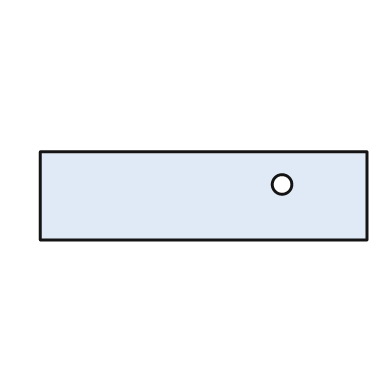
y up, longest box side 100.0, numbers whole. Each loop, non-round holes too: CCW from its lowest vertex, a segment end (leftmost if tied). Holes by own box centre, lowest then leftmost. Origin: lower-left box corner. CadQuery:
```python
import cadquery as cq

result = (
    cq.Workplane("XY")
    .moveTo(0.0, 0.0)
    .lineTo(100.0, 0.0)
    .lineTo(100.0, 27.0)
    .lineTo(0.0, 27.0)
    .close()
    .moveTo(74.0, 17.0)
    .circle(3.0)
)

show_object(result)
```